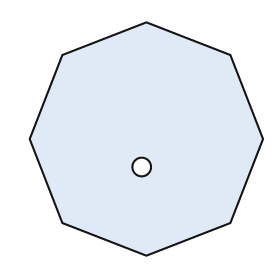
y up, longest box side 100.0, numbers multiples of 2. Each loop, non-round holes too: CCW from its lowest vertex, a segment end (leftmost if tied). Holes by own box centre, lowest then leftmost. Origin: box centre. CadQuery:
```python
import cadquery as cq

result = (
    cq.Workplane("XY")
    .moveTo(0.0, -50.0)
    .lineTo(36.0, -36.0)
    .lineTo(50.0, 0.0)
    .lineTo(36.0, 36.0)
    .lineTo(0.0, 50.0)
    .lineTo(-36.0, 36.0)
    .lineTo(-50.0, 0.0)
    .lineTo(-36.0, -36.0)
    .close()
    .moveTo(-2.0, -12.0)
    .circle(4.0)
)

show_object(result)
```